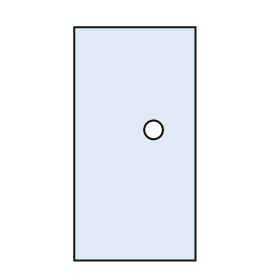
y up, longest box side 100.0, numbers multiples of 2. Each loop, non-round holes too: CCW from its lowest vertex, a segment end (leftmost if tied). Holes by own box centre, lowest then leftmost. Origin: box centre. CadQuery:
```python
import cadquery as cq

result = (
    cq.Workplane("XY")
    .moveTo(-26.0, -50.0)
    .lineTo(26.0, -50.0)
    .lineTo(26.0, 50.0)
    .lineTo(-26.0, 50.0)
    .close()
    .moveTo(8.0, 6.0)
    .circle(4.0)
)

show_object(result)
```